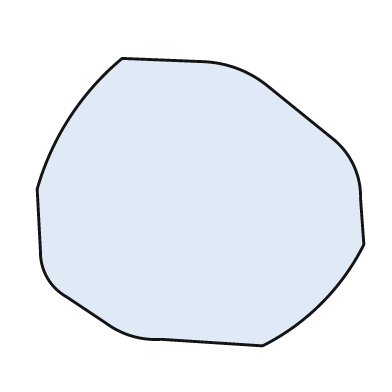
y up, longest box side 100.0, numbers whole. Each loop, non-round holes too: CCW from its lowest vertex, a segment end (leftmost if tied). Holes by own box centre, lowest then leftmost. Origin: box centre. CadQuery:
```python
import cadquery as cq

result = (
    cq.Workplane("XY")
    .moveTo(19.0, -44.0)
    .threePointArc((37.0, -31.0), (50.0, -13.0))
    .lineTo(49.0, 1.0)
    .threePointArc((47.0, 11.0), (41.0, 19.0))
    .lineTo(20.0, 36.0)
    .threePointArc((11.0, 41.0), (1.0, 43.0))
    .lineTo(-24.0, 44.0)
    .threePointArc((-40.0, 26.0), (-50.0, 4.0))
    .lineTo(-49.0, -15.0)
    .threePointArc((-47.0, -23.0), (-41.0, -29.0))
    .lineTo(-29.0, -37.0)
    .threePointArc((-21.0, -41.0), (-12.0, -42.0))
    .close()
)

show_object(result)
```